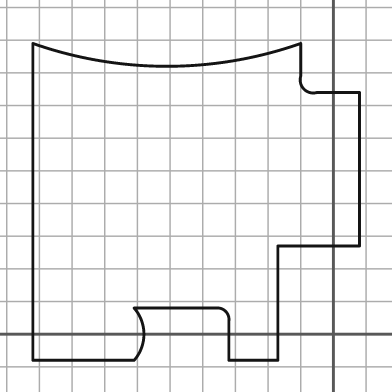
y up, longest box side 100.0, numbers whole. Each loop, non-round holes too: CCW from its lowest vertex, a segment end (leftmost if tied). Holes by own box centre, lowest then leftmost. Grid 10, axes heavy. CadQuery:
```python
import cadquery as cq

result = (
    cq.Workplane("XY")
    .moveTo(-92.0, -8.0)
    .lineTo(-61.0, -8.0)
    .threePointArc((-58.0, 0.0), (-61.0, 8.0))
    .lineTo(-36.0, 8.0)
    .threePointArc((-33.0, 7.0), (-32.0, 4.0))
    .lineTo(-32.0, -8.0)
    .lineTo(-17.0, -8.0)
    .lineTo(-17.0, 27.0)
    .lineTo(8.0, 27.0)
    .lineTo(8.0, 74.0)
    .lineTo(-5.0, 74.0)
    .threePointArc((-9.0, 75.0), (-10.0, 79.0))
    .lineTo(-10.0, 89.0)
    .threePointArc((-51.0, 82.0), (-92.0, 89.0))
    .close()
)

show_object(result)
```